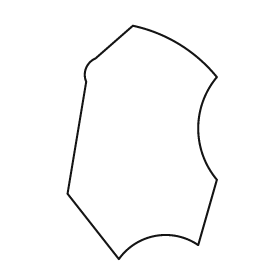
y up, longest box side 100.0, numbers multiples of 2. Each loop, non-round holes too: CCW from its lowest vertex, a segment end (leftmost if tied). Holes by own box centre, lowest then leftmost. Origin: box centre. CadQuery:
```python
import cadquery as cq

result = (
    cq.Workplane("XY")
    .moveTo(-10.0, -50.0)
    .threePointArc((6.0, -40.0), (24.0, -44.0))
    .lineTo(32.0, -16.0)
    .threePointArc((24.0, 6.0), (32.0, 28.0))
    .threePointArc((16.0, 42.0), (-4.0, 50.0))
    .lineTo(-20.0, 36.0)
    .threePointArc((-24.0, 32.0), (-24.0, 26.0))
    .lineTo(-32.0, -22.0)
    .close()
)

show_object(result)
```